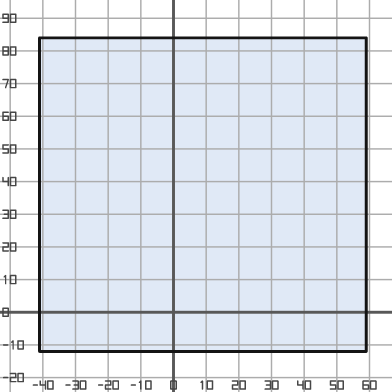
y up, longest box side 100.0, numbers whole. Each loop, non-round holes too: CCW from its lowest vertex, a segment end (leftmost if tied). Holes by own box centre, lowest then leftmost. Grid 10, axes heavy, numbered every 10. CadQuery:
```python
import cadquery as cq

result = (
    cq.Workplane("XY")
    .moveTo(-41.0, -12.0)
    .lineTo(59.0, -12.0)
    .lineTo(59.0, 84.0)
    .lineTo(-41.0, 84.0)
    .close()
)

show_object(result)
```